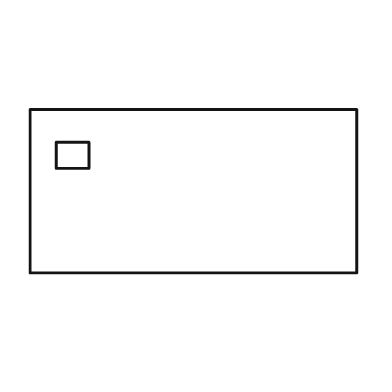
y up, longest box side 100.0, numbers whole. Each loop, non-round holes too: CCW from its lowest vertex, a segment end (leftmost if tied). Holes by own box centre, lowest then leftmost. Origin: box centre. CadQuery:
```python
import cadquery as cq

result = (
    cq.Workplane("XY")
    .moveTo(-50.0, -25.0)
    .lineTo(50.0, -25.0)
    .lineTo(50.0, 25.0)
    .lineTo(-50.0, 25.0)
    .close()
    .moveTo(-42.0, 7.0)
    .lineTo(-32.0, 7.0)
    .lineTo(-32.0, 15.0)
    .lineTo(-42.0, 15.0)
    .close()
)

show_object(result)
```